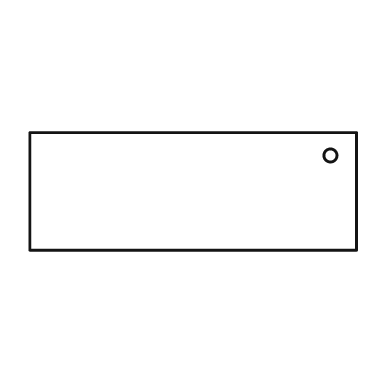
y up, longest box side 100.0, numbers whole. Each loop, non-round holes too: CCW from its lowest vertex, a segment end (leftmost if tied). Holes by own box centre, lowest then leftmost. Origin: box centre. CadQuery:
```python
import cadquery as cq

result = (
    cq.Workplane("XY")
    .moveTo(-50.0, -18.0)
    .lineTo(50.0, -18.0)
    .lineTo(50.0, 18.0)
    .lineTo(-50.0, 18.0)
    .close()
    .moveTo(42.0, 11.0)
    .circle(2.0)
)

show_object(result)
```